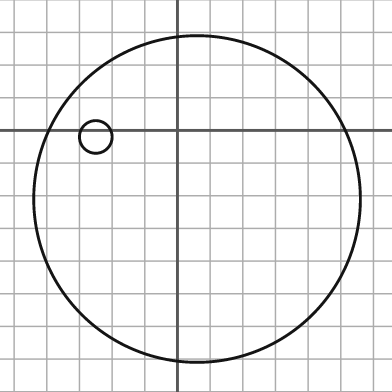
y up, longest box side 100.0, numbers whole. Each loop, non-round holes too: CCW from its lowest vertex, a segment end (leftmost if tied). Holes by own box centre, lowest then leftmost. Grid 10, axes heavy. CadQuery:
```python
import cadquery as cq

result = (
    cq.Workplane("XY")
    .moveTo(6.0, -21.0)
    .circle(50.0)
    .moveTo(-25.0, -2.0)
    .circle(5.0)
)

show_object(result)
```